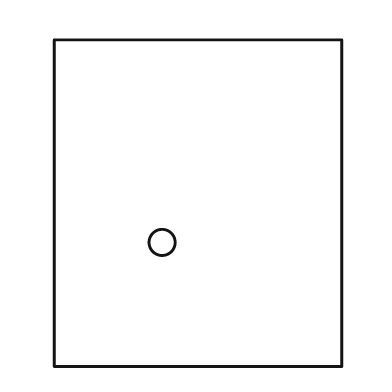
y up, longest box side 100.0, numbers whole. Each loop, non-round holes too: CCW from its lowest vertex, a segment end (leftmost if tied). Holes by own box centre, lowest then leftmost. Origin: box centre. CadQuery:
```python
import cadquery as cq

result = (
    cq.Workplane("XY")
    .moveTo(-44.0, -50.0)
    .lineTo(44.0, -50.0)
    .lineTo(44.0, 50.0)
    .lineTo(-44.0, 50.0)
    .close()
    .moveTo(-11.0, -12.0)
    .circle(4.0)
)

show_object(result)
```